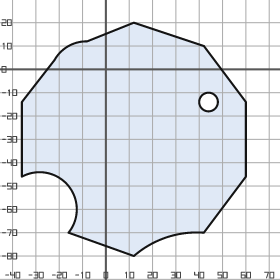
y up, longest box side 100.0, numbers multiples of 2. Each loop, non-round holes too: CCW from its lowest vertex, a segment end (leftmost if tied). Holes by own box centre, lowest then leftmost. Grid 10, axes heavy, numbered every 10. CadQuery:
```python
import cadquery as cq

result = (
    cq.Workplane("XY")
    .moveTo(12.0, -80.0)
    .threePointArc((26.0, -72.0), (42.0, -70.0))
    .lineTo(60.0, -46.0)
    .lineTo(60.0, -14.0)
    .lineTo(42.0, 10.0)
    .lineTo(12.0, 20.0)
    .lineTo(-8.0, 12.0)
    .threePointArc((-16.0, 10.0), (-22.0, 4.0))
    .lineTo(-36.0, -14.0)
    .lineTo(-36.0, -46.0)
    .threePointArc((-16.0, -50.0), (-16.0, -70.0))
    .close()
    .moveTo(44.0, -14.0)
    .circle(4.0)
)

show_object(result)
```